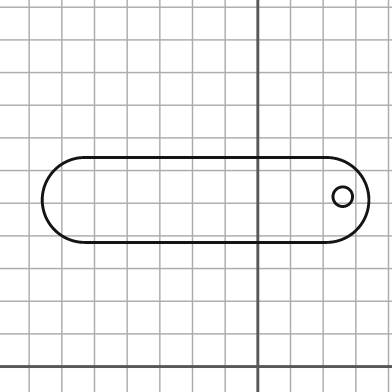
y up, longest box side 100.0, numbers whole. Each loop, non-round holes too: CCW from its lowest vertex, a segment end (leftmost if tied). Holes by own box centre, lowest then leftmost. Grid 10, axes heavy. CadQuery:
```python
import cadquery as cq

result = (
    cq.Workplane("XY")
    .moveTo(-53.0, 38.0)
    .lineTo(21.0, 38.0)
    .threePointArc((34.0, 51.0), (21.0, 64.0))
    .lineTo(-53.0, 64.0)
    .threePointArc((-66.0, 51.0), (-53.0, 38.0))
    .close()
    .moveTo(26.0, 52.0)
    .circle(3.0)
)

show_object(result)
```